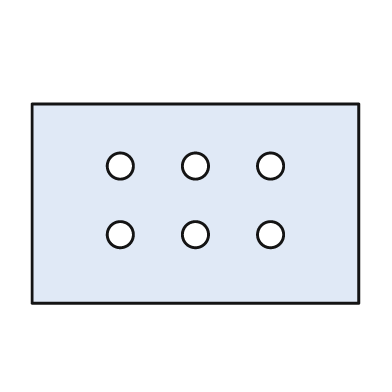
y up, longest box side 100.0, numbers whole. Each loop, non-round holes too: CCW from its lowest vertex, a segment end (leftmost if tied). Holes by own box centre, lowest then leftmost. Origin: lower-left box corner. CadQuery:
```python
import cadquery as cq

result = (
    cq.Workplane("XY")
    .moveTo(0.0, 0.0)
    .lineTo(100.0, 0.0)
    .lineTo(100.0, 61.0)
    .lineTo(0.0, 61.0)
    .close()
    .moveTo(27.0, 21.0)
    .circle(4.0)
    .moveTo(50.0, 21.0)
    .circle(4.0)
    .moveTo(73.0, 21.0)
    .circle(4.0)
    .moveTo(27.0, 42.0)
    .circle(4.0)
    .moveTo(50.0, 42.0)
    .circle(4.0)
    .moveTo(73.0, 42.0)
    .circle(4.0)
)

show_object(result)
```